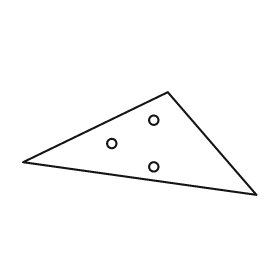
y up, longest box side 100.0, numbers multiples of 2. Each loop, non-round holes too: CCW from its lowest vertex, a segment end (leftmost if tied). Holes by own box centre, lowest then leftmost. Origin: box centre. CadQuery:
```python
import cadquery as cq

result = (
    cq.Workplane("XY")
    .moveTo(50.0, -22.0)
    .lineTo(12.0, 22.0)
    .lineTo(-50.0, -8.0)
    .close()
    .moveTo(6.0, -10.0)
    .circle(2.0)
    .moveTo(-12.0, 0.0)
    .circle(2.0)
    .moveTo(6.0, 10.0)
    .circle(2.0)
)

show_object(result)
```